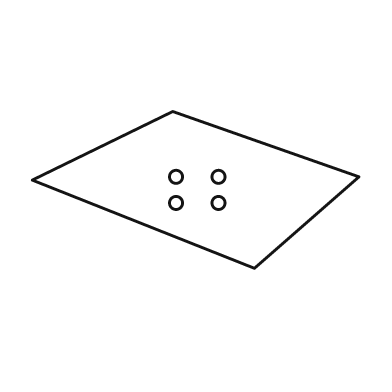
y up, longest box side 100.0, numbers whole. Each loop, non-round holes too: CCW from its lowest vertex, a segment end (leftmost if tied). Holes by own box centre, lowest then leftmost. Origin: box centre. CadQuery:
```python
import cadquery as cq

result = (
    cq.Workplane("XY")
    .moveTo(18.0, -24.0)
    .lineTo(50.0, 4.0)
    .lineTo(-7.0, 24.0)
    .lineTo(-50.0, 3.0)
    .close()
    .moveTo(-6.0, -4.0)
    .circle(2.0)
    .moveTo(7.0, -4.0)
    .circle(2.0)
    .moveTo(-6.0, 4.0)
    .circle(2.0)
    .moveTo(7.0, 4.0)
    .circle(2.0)
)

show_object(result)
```